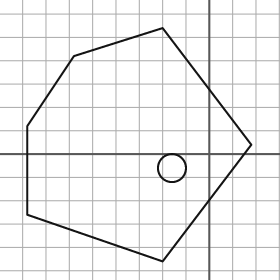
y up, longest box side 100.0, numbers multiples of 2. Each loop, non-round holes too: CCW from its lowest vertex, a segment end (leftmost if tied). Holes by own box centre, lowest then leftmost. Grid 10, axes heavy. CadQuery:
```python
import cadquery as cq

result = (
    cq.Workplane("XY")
    .moveTo(-20.0, -46.0)
    .lineTo(18.0, 4.0)
    .lineTo(-20.0, 54.0)
    .lineTo(-58.0, 42.0)
    .lineTo(-78.0, 12.0)
    .lineTo(-78.0, -26.0)
    .close()
    .moveTo(-16.0, -6.0)
    .circle(6.0)
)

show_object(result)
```